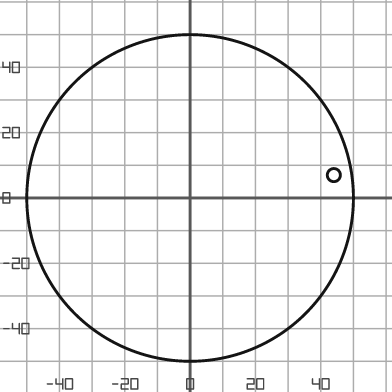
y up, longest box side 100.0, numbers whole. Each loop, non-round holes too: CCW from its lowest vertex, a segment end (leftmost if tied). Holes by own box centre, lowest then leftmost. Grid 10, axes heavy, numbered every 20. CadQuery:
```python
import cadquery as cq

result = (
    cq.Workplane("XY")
    .moveTo(0.0, 0.0)
    .circle(50.0)
    .moveTo(44.0, 7.0)
    .circle(2.0)
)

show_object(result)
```